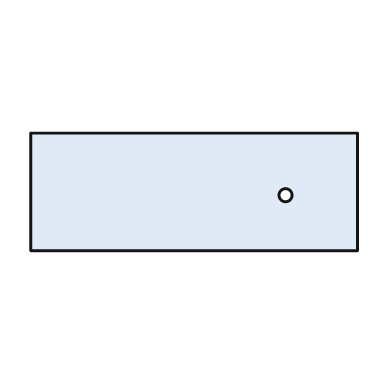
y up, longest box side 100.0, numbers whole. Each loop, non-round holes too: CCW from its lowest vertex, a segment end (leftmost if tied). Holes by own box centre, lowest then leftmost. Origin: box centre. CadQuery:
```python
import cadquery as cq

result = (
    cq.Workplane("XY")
    .moveTo(-50.0, -18.0)
    .lineTo(50.0, -18.0)
    .lineTo(50.0, 18.0)
    .lineTo(-50.0, 18.0)
    .close()
    .moveTo(28.0, -1.0)
    .circle(2.0)
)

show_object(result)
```